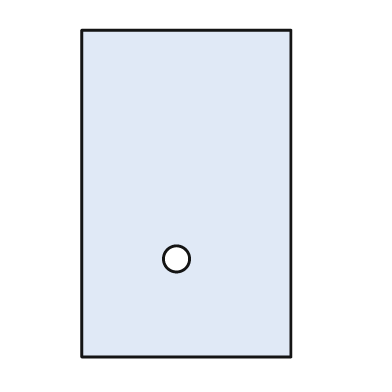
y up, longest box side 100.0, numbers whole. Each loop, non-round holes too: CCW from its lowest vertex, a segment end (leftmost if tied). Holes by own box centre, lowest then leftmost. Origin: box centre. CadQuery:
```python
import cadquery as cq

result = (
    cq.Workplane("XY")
    .moveTo(-32.0, -50.0)
    .lineTo(32.0, -50.0)
    .lineTo(32.0, 50.0)
    .lineTo(-32.0, 50.0)
    .close()
    .moveTo(-3.0, -20.0)
    .circle(4.0)
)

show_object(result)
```